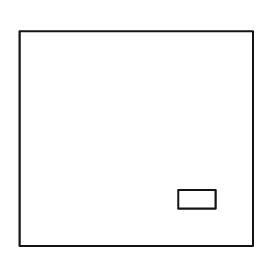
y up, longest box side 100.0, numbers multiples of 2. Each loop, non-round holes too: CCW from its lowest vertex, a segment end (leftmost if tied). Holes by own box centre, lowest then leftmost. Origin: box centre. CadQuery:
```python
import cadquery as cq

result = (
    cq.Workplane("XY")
    .moveTo(-50.0, -46.0)
    .lineTo(50.0, -46.0)
    .lineTo(50.0, 46.0)
    .lineTo(-50.0, 46.0)
    .close()
    .moveTo(18.0, -30.0)
    .lineTo(34.0, -30.0)
    .lineTo(34.0, -22.0)
    .lineTo(18.0, -22.0)
    .close()
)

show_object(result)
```